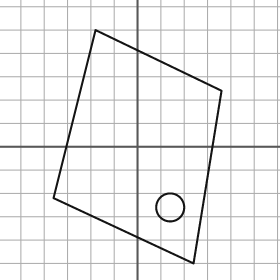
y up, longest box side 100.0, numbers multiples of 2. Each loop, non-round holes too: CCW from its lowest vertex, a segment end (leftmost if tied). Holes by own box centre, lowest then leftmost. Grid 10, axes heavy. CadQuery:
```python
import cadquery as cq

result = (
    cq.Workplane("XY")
    .moveTo(24.0, -50.0)
    .lineTo(36.0, 24.0)
    .lineTo(-18.0, 50.0)
    .lineTo(-36.0, -22.0)
    .close()
    .moveTo(14.0, -26.0)
    .circle(6.0)
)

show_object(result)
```